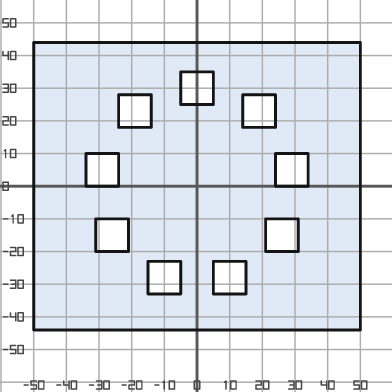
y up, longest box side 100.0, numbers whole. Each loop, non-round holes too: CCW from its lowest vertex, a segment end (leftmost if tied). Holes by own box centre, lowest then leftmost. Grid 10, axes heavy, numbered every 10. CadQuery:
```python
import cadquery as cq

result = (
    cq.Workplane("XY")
    .moveTo(-50.0, -44.0)
    .lineTo(50.0, -44.0)
    .lineTo(50.0, 44.0)
    .lineTo(-50.0, 44.0)
    .close()
    .moveTo(-15.0, -33.0)
    .lineTo(-5.0, -33.0)
    .lineTo(-5.0, -23.0)
    .lineTo(-15.0, -23.0)
    .close()
    .moveTo(5.0, -33.0)
    .lineTo(15.0, -33.0)
    .lineTo(15.0, -23.0)
    .lineTo(5.0, -23.0)
    .close()
    .moveTo(-31.0, -20.0)
    .lineTo(-21.0, -20.0)
    .lineTo(-21.0, -10.0)
    .lineTo(-31.0, -10.0)
    .close()
    .moveTo(21.0, -20.0)
    .lineTo(31.0, -20.0)
    .lineTo(31.0, -10.0)
    .lineTo(21.0, -10.0)
    .close()
    .moveTo(-34.0, 0.0)
    .lineTo(-24.0, 0.0)
    .lineTo(-24.0, 10.0)
    .lineTo(-34.0, 10.0)
    .close()
    .moveTo(24.0, 0.0)
    .lineTo(34.0, 0.0)
    .lineTo(34.0, 10.0)
    .lineTo(24.0, 10.0)
    .close()
    .moveTo(-24.0, 18.0)
    .lineTo(-14.0, 18.0)
    .lineTo(-14.0, 28.0)
    .lineTo(-24.0, 28.0)
    .close()
    .moveTo(14.0, 18.0)
    .lineTo(24.0, 18.0)
    .lineTo(24.0, 28.0)
    .lineTo(14.0, 28.0)
    .close()
    .moveTo(-5.0, 25.0)
    .lineTo(5.0, 25.0)
    .lineTo(5.0, 35.0)
    .lineTo(-5.0, 35.0)
    .close()
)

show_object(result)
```